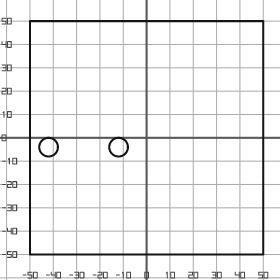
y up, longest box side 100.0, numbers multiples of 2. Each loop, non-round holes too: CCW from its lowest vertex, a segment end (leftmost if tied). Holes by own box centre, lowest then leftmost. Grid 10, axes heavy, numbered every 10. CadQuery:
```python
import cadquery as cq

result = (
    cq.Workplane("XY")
    .moveTo(-50.0, -50.0)
    .lineTo(50.0, -50.0)
    .lineTo(50.0, 50.0)
    .lineTo(-50.0, 50.0)
    .close()
    .moveTo(-42.0, -4.0)
    .circle(4.0)
    .moveTo(-12.0, -4.0)
    .circle(4.0)
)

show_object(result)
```